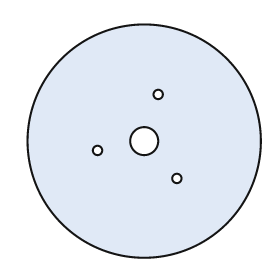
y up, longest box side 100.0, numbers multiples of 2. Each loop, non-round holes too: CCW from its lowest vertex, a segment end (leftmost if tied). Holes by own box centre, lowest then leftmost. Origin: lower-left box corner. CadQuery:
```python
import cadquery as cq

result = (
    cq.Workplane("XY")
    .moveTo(50.0, 50.0)
    .circle(50.0)
    .moveTo(64.0, 34.0)
    .circle(2.0)
    .moveTo(30.0, 46.0)
    .circle(2.0)
    .moveTo(50.0, 50.0)
    .circle(6.0)
    .moveTo(56.0, 70.0)
    .circle(2.0)
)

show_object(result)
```